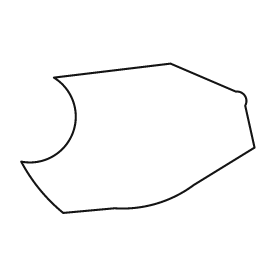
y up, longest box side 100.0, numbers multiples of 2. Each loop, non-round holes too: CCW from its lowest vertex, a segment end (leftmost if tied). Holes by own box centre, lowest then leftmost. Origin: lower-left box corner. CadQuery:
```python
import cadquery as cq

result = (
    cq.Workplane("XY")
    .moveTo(18.0, 0.0)
    .lineTo(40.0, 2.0)
    .threePointArc((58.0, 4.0), (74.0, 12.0))
    .lineTo(100.0, 28.0)
    .lineTo(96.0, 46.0)
    .threePointArc((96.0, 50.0), (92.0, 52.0))
    .lineTo(64.0, 64.0)
    .lineTo(14.0, 58.0)
    .threePointArc((22.0, 34.0), (0.0, 22.0))
    .threePointArc((8.0, 10.0), (18.0, 0.0))
    .close()
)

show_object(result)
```